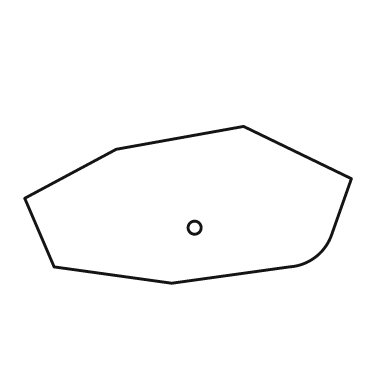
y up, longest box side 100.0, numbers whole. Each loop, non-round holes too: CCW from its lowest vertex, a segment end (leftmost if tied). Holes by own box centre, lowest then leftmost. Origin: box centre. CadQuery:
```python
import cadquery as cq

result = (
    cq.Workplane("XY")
    .moveTo(-5.0, -24.0)
    .lineTo(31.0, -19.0)
    .threePointArc((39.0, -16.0), (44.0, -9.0))
    .lineTo(50.0, 8.0)
    .lineTo(17.0, 24.0)
    .lineTo(-22.0, 17.0)
    .lineTo(-50.0, 2.0)
    .lineTo(-41.0, -19.0)
    .close()
    .moveTo(2.0, -7.0)
    .circle(2.0)
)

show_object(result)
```